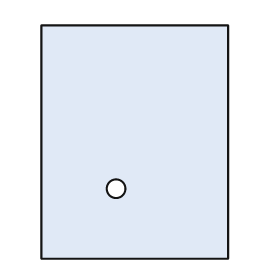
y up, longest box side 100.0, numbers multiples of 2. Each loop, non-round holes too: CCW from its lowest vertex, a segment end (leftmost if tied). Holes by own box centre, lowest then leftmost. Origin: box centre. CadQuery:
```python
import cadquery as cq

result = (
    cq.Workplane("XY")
    .moveTo(-40.0, -50.0)
    .lineTo(40.0, -50.0)
    .lineTo(40.0, 50.0)
    .lineTo(-40.0, 50.0)
    .close()
    .moveTo(-8.0, -20.0)
    .circle(4.0)
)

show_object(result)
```